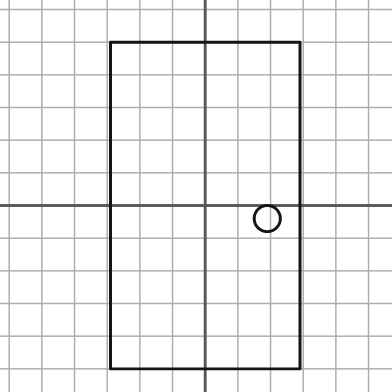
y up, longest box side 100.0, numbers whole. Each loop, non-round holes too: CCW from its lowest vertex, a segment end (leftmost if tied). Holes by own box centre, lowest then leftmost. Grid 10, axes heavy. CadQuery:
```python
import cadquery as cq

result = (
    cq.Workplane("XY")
    .moveTo(-29.0, -50.0)
    .lineTo(29.0, -50.0)
    .lineTo(29.0, 50.0)
    .lineTo(-29.0, 50.0)
    .close()
    .moveTo(19.0, -4.0)
    .circle(4.0)
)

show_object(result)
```